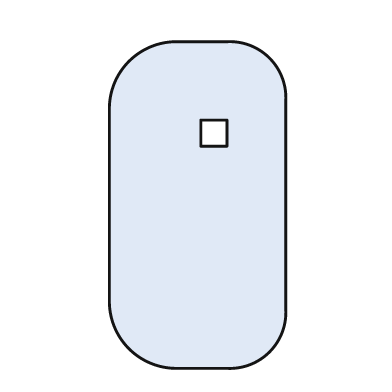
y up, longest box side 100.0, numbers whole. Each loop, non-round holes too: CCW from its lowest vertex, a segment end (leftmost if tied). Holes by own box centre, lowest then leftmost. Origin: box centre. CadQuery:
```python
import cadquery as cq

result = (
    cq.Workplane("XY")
    .moveTo(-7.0, -50.0)
    .lineTo(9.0, -50.0)
    .threePointArc((22.0, -45.0), (27.0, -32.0))
    .lineTo(27.0, 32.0)
    .threePointArc((22.0, 45.0), (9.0, 50.0))
    .lineTo(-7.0, 50.0)
    .threePointArc((-21.0, 44.0), (-27.0, 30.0))
    .lineTo(-27.0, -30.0)
    .threePointArc((-21.0, -44.0), (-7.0, -50.0))
    .close()
    .moveTo(1.0, 18.0)
    .lineTo(9.0, 18.0)
    .lineTo(9.0, 26.0)
    .lineTo(1.0, 26.0)
    .close()
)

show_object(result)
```